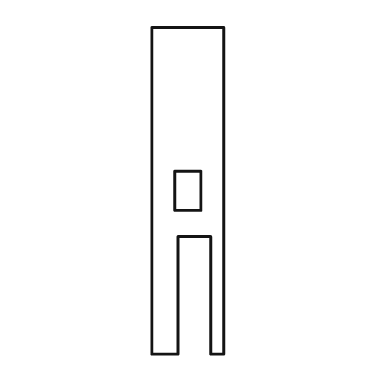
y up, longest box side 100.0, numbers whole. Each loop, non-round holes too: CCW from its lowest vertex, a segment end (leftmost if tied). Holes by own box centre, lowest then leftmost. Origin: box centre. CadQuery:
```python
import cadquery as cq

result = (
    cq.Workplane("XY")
    .moveTo(-11.0, -50.0)
    .lineTo(-3.0, -50.0)
    .lineTo(-3.0, -14.0)
    .lineTo(7.0, -14.0)
    .lineTo(7.0, -50.0)
    .lineTo(11.0, -50.0)
    .lineTo(11.0, 50.0)
    .lineTo(-11.0, 50.0)
    .close()
    .moveTo(-4.0, -6.0)
    .lineTo(4.0, -6.0)
    .lineTo(4.0, 6.0)
    .lineTo(-4.0, 6.0)
    .close()
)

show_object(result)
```